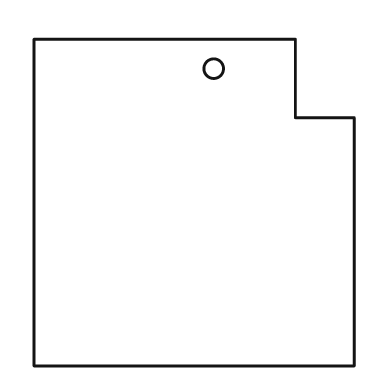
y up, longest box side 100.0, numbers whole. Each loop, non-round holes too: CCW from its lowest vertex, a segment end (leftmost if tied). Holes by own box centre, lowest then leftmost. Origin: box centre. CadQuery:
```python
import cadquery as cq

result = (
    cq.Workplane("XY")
    .moveTo(-49.0, -50.0)
    .lineTo(49.0, -50.0)
    .lineTo(49.0, 26.0)
    .lineTo(31.0, 26.0)
    .lineTo(31.0, 50.0)
    .lineTo(-49.0, 50.0)
    .close()
    .moveTo(6.0, 41.0)
    .circle(3.0)
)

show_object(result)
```